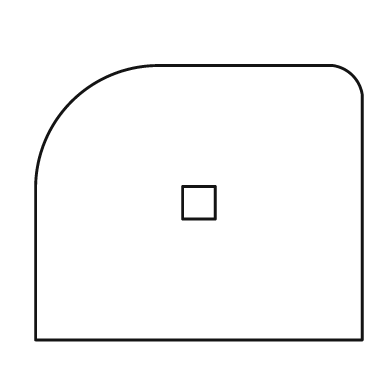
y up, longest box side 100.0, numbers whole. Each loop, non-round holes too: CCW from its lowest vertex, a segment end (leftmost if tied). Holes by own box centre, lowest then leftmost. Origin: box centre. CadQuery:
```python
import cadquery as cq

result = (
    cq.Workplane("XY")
    .moveTo(-50.0, -42.0)
    .lineTo(50.0, -42.0)
    .lineTo(50.0, 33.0)
    .threePointArc((47.0, 39.0), (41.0, 42.0))
    .lineTo(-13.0, 42.0)
    .threePointArc((-39.0, 31.0), (-50.0, 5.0))
    .close()
    .moveTo(-5.0, -5.0)
    .lineTo(5.0, -5.0)
    .lineTo(5.0, 5.0)
    .lineTo(-5.0, 5.0)
    .close()
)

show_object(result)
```